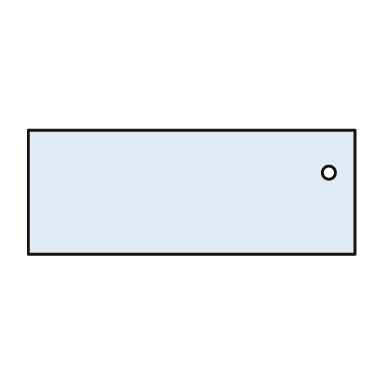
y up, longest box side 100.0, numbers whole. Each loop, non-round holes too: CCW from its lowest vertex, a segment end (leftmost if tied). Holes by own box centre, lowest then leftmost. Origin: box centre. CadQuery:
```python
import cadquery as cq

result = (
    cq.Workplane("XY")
    .moveTo(-50.0, -19.0)
    .lineTo(50.0, -19.0)
    .lineTo(50.0, 19.0)
    .lineTo(-50.0, 19.0)
    .close()
    .moveTo(42.0, 6.0)
    .circle(2.0)
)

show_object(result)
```